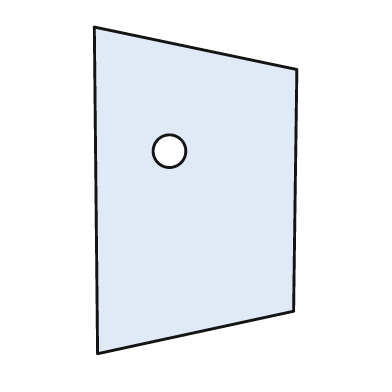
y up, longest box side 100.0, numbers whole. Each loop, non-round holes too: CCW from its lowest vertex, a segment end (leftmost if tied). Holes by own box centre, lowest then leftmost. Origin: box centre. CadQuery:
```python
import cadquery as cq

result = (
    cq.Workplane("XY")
    .moveTo(-30.0, -50.0)
    .lineTo(30.0, -37.0)
    .lineTo(31.0, 37.0)
    .lineTo(-31.0, 50.0)
    .close()
    .moveTo(-8.0, 12.0)
    .circle(5.0)
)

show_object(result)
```